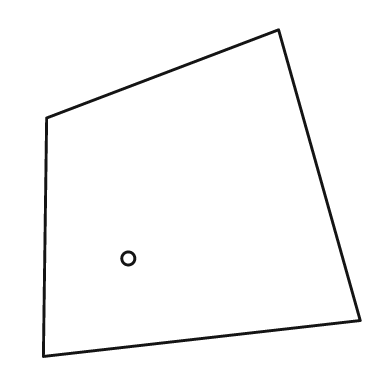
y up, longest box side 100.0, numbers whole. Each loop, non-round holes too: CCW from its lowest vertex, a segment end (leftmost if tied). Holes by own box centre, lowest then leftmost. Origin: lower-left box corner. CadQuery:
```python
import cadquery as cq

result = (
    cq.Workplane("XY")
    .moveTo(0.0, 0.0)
    .lineTo(97.0, 11.0)
    .lineTo(72.0, 100.0)
    .lineTo(1.0, 73.0)
    .close()
    .moveTo(26.0, 30.0)
    .circle(2.0)
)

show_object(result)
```